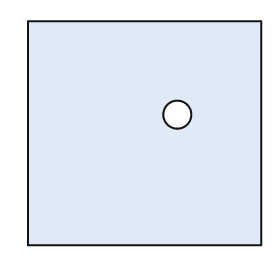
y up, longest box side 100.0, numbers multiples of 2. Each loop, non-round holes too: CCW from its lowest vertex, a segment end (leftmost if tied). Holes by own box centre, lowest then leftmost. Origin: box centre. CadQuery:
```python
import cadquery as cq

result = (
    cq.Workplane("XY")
    .moveTo(-50.0, -48.0)
    .lineTo(50.0, -48.0)
    .lineTo(50.0, 48.0)
    .lineTo(-50.0, 48.0)
    .close()
    .moveTo(14.0, 8.0)
    .circle(6.0)
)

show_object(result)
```